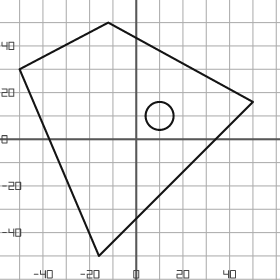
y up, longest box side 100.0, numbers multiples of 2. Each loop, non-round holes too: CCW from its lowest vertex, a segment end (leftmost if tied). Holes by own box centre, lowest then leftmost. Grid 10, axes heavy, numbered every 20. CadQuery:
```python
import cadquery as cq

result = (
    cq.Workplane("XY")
    .moveTo(-16.0, -50.0)
    .lineTo(50.0, 16.0)
    .lineTo(-12.0, 50.0)
    .lineTo(-50.0, 30.0)
    .close()
    .moveTo(10.0, 10.0)
    .circle(6.0)
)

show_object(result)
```